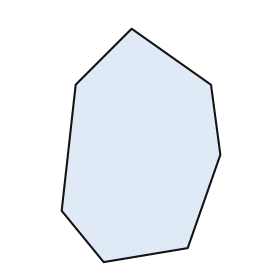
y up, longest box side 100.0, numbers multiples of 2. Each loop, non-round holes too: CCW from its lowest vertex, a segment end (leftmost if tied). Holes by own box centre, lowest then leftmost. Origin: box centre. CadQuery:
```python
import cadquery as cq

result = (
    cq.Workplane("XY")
    .moveTo(-16.0, -50.0)
    .lineTo(20.0, -44.0)
    .lineTo(34.0, -4.0)
    .lineTo(30.0, 26.0)
    .lineTo(-4.0, 50.0)
    .lineTo(-28.0, 26.0)
    .lineTo(-34.0, -28.0)
    .close()
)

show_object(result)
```